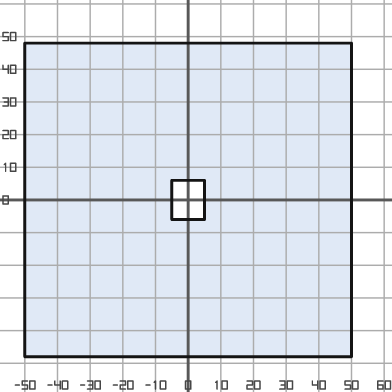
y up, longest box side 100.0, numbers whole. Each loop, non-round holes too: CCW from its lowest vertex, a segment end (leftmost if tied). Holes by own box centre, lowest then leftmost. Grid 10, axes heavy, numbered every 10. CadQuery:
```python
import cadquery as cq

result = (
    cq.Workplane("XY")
    .moveTo(-50.0, -48.0)
    .lineTo(50.0, -48.0)
    .lineTo(50.0, 48.0)
    .lineTo(-50.0, 48.0)
    .close()
    .moveTo(-5.0, -6.0)
    .lineTo(5.0, -6.0)
    .lineTo(5.0, 6.0)
    .lineTo(-5.0, 6.0)
    .close()
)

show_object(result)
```